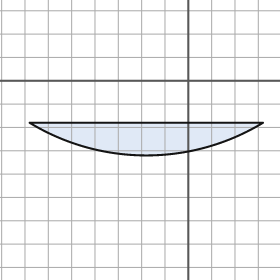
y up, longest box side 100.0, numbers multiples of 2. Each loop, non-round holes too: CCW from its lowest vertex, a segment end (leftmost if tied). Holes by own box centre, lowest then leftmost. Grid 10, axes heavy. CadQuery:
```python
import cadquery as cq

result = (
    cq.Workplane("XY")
    .moveTo(-68.0, -18.0)
    .threePointArc((-18.0, -32.0), (32.0, -18.0))
    .close()
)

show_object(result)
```